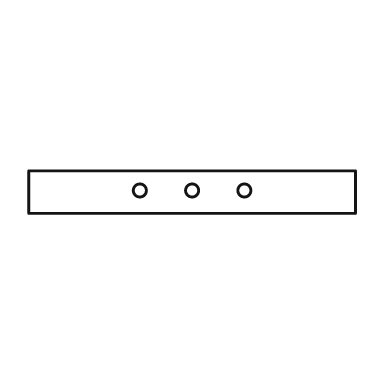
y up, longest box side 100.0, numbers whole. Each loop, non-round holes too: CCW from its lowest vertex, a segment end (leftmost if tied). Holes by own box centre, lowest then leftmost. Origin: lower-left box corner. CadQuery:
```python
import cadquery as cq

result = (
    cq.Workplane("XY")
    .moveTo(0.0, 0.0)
    .lineTo(100.0, 0.0)
    .lineTo(100.0, 13.0)
    .lineTo(0.0, 13.0)
    .close()
    .moveTo(34.0, 7.0)
    .circle(2.0)
    .moveTo(50.0, 7.0)
    .circle(2.0)
    .moveTo(66.0, 7.0)
    .circle(2.0)
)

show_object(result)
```